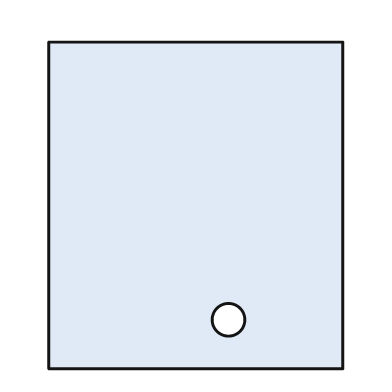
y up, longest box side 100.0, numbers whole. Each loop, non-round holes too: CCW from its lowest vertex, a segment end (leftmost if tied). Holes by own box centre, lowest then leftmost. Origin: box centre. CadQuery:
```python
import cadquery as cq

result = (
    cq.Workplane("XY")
    .moveTo(-45.0, -50.0)
    .lineTo(45.0, -50.0)
    .lineTo(45.0, 50.0)
    .lineTo(-45.0, 50.0)
    .close()
    .moveTo(10.0, -35.0)
    .circle(5.0)
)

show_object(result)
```